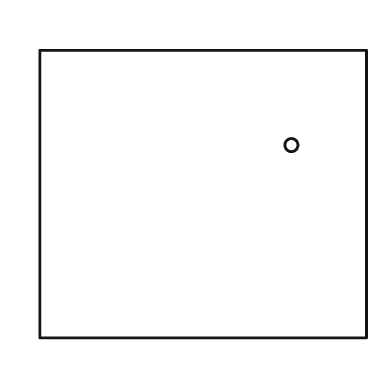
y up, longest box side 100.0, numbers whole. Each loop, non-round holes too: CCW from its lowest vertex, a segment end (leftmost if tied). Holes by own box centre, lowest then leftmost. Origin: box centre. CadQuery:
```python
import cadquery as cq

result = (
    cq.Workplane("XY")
    .moveTo(-50.0, -44.0)
    .lineTo(50.0, -44.0)
    .lineTo(50.0, 44.0)
    .lineTo(-50.0, 44.0)
    .close()
    .moveTo(27.0, 15.0)
    .circle(2.0)
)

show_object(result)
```